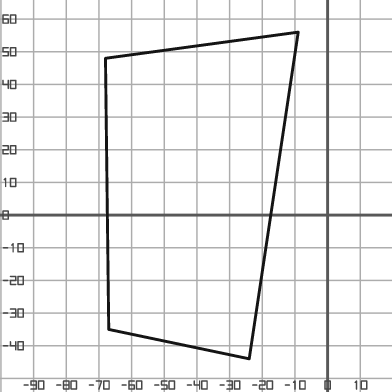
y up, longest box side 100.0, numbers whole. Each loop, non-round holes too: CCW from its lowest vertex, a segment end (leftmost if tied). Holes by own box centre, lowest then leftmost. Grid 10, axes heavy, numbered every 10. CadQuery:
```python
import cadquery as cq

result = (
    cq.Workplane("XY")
    .moveTo(-24.0, -44.0)
    .lineTo(-9.0, 56.0)
    .lineTo(-68.0, 48.0)
    .lineTo(-67.0, -35.0)
    .close()
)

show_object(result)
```